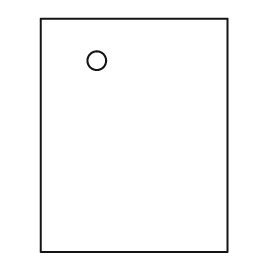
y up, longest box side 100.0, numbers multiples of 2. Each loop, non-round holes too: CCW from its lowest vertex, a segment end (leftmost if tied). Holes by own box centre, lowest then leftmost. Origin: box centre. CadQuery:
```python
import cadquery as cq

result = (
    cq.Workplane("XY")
    .moveTo(-40.0, -50.0)
    .lineTo(40.0, -50.0)
    .lineTo(40.0, 50.0)
    .lineTo(-40.0, 50.0)
    .close()
    .moveTo(-16.0, 32.0)
    .circle(4.0)
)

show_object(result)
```